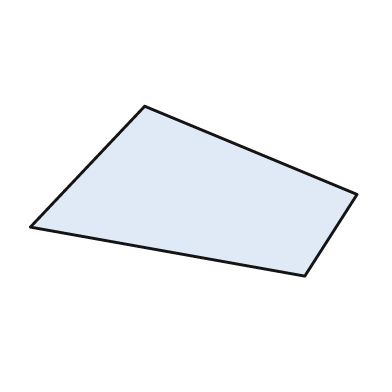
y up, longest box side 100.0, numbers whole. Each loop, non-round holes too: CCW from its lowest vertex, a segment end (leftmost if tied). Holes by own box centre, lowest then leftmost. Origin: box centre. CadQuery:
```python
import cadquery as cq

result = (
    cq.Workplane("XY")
    .moveTo(34.0, -26.0)
    .lineTo(50.0, -1.0)
    .lineTo(-15.0, 26.0)
    .lineTo(-50.0, -11.0)
    .close()
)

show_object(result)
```